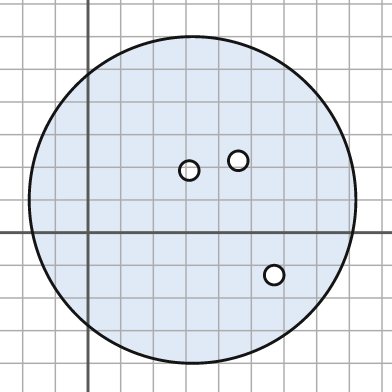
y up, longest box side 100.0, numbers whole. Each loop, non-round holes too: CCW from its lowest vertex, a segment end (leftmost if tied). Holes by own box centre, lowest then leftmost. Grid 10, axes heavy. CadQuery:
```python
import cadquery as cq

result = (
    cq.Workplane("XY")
    .moveTo(32.0, 10.0)
    .circle(50.0)
    .moveTo(57.0, -13.0)
    .circle(3.0)
    .moveTo(31.0, 19.0)
    .circle(3.0)
    .moveTo(46.0, 22.0)
    .circle(3.0)
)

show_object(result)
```